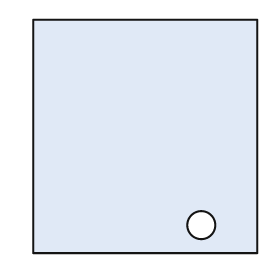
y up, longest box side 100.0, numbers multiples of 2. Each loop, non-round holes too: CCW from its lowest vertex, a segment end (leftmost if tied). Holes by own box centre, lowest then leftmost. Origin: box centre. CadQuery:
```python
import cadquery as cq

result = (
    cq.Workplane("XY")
    .moveTo(-48.0, -50.0)
    .lineTo(48.0, -50.0)
    .lineTo(48.0, 50.0)
    .lineTo(-48.0, 50.0)
    .close()
    .moveTo(24.0, -38.0)
    .circle(6.0)
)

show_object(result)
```